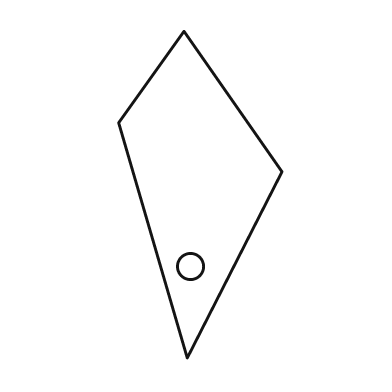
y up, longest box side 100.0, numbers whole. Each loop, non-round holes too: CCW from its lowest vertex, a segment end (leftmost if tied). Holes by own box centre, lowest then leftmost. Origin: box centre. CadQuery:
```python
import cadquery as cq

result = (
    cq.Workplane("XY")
    .moveTo(-4.0, -50.0)
    .lineTo(25.0, 7.0)
    .lineTo(-5.0, 50.0)
    .lineTo(-25.0, 22.0)
    .close()
    .moveTo(-3.0, -22.0)
    .circle(4.0)
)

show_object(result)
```